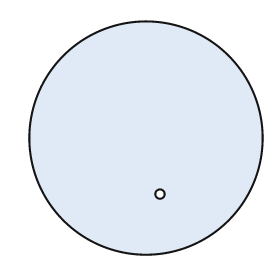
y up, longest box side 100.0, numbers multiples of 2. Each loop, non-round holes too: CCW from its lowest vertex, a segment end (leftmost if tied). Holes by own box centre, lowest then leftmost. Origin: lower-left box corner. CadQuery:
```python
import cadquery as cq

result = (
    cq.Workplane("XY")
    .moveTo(50.0, 50.0)
    .circle(50.0)
    .moveTo(56.0, 26.0)
    .circle(2.0)
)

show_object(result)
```